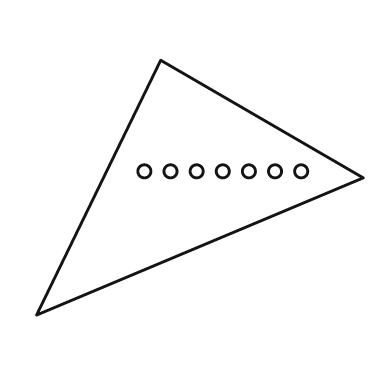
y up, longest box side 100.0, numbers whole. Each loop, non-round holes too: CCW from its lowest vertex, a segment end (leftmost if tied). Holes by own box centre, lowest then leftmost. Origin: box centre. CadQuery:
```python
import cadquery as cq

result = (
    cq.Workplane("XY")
    .moveTo(-50.0, -39.0)
    .lineTo(50.0, 3.0)
    .lineTo(-12.0, 39.0)
    .close()
    .moveTo(-17.0, 5.0)
    .circle(2.0)
    .moveTo(-9.0, 5.0)
    .circle(2.0)
    .moveTo(-1.0, 5.0)
    .circle(2.0)
    .moveTo(7.0, 5.0)
    .circle(2.0)
    .moveTo(15.0, 5.0)
    .circle(2.0)
    .moveTo(23.0, 5.0)
    .circle(2.0)
    .moveTo(31.0, 5.0)
    .circle(2.0)
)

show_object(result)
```